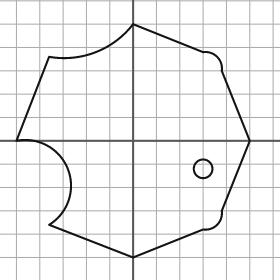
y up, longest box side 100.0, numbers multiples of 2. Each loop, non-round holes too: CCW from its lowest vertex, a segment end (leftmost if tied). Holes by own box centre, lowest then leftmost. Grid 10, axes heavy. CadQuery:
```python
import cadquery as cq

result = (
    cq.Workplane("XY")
    .moveTo(0.0, -50.0)
    .lineTo(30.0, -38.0)
    .threePointArc((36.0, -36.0), (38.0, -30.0))
    .lineTo(50.0, 0.0)
    .lineTo(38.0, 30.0)
    .threePointArc((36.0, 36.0), (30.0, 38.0))
    .lineTo(0.0, 50.0)
    .threePointArc((-16.0, 38.0), (-36.0, 36.0))
    .lineTo(-50.0, 0.0)
    .threePointArc((-28.0, -12.0), (-36.0, -36.0))
    .close()
    .moveTo(30.0, -12.0)
    .circle(4.0)
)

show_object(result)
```